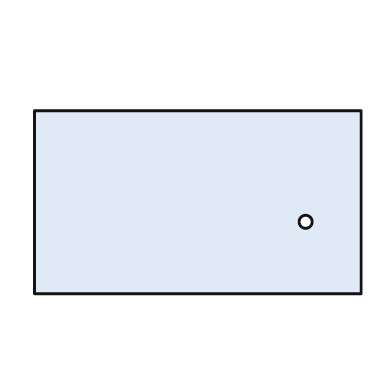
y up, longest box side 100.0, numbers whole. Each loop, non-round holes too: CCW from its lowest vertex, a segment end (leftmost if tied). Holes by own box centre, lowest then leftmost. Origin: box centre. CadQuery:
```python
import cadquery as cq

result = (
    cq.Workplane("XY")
    .moveTo(-50.0, -28.0)
    .lineTo(50.0, -28.0)
    .lineTo(50.0, 28.0)
    .lineTo(-50.0, 28.0)
    .close()
    .moveTo(33.0, -6.0)
    .circle(2.0)
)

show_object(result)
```